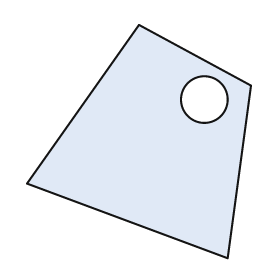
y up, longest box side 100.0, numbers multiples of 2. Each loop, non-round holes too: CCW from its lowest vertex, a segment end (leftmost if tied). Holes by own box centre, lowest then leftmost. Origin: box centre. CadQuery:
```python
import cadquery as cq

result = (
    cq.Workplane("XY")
    .moveTo(38.0, -50.0)
    .lineTo(48.0, 24.0)
    .lineTo(0.0, 50.0)
    .lineTo(-48.0, -18.0)
    .close()
    .moveTo(28.0, 18.0)
    .circle(10.0)
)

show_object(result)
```